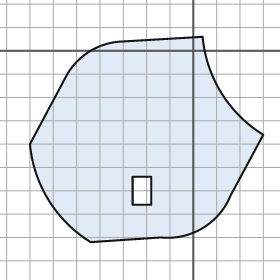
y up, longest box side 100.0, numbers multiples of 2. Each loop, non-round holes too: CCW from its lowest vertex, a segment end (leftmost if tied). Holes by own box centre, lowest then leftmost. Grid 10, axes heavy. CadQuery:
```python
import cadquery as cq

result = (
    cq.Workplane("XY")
    .moveTo(-44.0, -82.0)
    .lineTo(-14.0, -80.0)
    .threePointArc((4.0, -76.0), (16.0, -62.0))
    .lineTo(30.0, -36.0)
    .threePointArc((12.0, -18.0), (4.0, 6.0))
    .lineTo(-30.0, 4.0)
    .threePointArc((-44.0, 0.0), (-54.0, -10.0))
    .lineTo(-70.0, -40.0)
    .threePointArc((-62.0, -64.0), (-44.0, -82.0))
    .close()
    .moveTo(-26.0, -66.0)
    .lineTo(-18.0, -66.0)
    .lineTo(-18.0, -54.0)
    .lineTo(-26.0, -54.0)
    .close()
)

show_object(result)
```